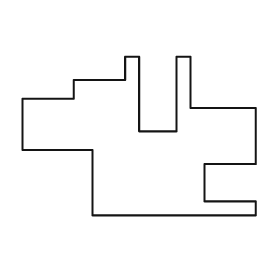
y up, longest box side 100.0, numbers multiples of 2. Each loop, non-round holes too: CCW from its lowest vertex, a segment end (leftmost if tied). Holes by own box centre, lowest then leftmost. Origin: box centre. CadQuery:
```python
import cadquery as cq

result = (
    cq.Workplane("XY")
    .moveTo(-20.0, -34.0)
    .lineTo(50.0, -34.0)
    .lineTo(50.0, -28.0)
    .lineTo(28.0, -28.0)
    .lineTo(28.0, -12.0)
    .lineTo(50.0, -12.0)
    .lineTo(50.0, 12.0)
    .lineTo(22.0, 12.0)
    .lineTo(22.0, 34.0)
    .lineTo(16.0, 34.0)
    .lineTo(16.0, 2.0)
    .lineTo(0.0, 2.0)
    .lineTo(0.0, 34.0)
    .lineTo(-6.0, 34.0)
    .lineTo(-6.0, 24.0)
    .lineTo(-28.0, 24.0)
    .lineTo(-28.0, 16.0)
    .lineTo(-50.0, 16.0)
    .lineTo(-50.0, -6.0)
    .lineTo(-20.0, -6.0)
    .close()
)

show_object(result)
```